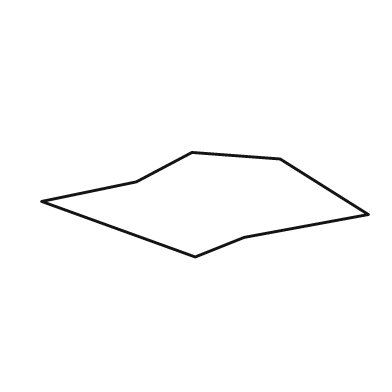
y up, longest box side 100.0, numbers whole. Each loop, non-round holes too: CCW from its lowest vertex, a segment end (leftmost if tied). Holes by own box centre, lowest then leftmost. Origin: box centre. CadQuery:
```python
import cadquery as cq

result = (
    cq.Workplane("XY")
    .moveTo(-3.0, -16.0)
    .lineTo(12.0, -10.0)
    .lineTo(50.0, -3.0)
    .lineTo(23.0, 14.0)
    .lineTo(-4.0, 16.0)
    .lineTo(-21.0, 7.0)
    .lineTo(-50.0, 1.0)
    .close()
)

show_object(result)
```